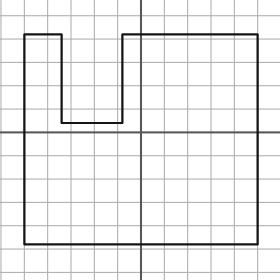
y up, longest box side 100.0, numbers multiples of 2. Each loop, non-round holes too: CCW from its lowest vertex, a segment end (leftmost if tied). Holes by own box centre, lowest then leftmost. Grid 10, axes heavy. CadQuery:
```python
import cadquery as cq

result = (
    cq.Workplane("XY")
    .moveTo(-50.0, -48.0)
    .lineTo(50.0, -48.0)
    .lineTo(50.0, 42.0)
    .lineTo(-8.0, 42.0)
    .lineTo(-8.0, 4.0)
    .lineTo(-34.0, 4.0)
    .lineTo(-34.0, 42.0)
    .lineTo(-50.0, 42.0)
    .close()
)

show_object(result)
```